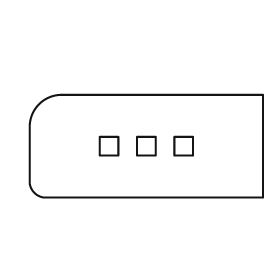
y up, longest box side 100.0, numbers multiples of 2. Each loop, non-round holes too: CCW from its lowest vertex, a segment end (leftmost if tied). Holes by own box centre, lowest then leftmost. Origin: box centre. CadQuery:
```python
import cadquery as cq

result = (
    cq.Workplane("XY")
    .moveTo(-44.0, -22.0)
    .lineTo(50.0, -22.0)
    .lineTo(50.0, 22.0)
    .lineTo(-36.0, 22.0)
    .threePointArc((-46.0, 18.0), (-50.0, 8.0))
    .lineTo(-50.0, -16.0)
    .threePointArc((-48.0, -20.0), (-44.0, -22.0))
    .close()
    .moveTo(-20.0, -4.0)
    .lineTo(-12.0, -4.0)
    .lineTo(-12.0, 4.0)
    .lineTo(-20.0, 4.0)
    .close()
    .moveTo(-4.0, -4.0)
    .lineTo(4.0, -4.0)
    .lineTo(4.0, 4.0)
    .lineTo(-4.0, 4.0)
    .close()
    .moveTo(12.0, -4.0)
    .lineTo(20.0, -4.0)
    .lineTo(20.0, 4.0)
    .lineTo(12.0, 4.0)
    .close()
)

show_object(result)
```